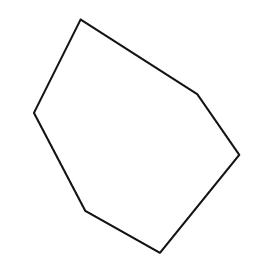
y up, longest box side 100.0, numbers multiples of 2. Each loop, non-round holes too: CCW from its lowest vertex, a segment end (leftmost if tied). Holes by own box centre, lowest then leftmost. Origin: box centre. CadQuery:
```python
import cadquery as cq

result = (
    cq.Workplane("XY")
    .moveTo(10.0, -50.0)
    .lineTo(44.0, -8.0)
    .lineTo(26.0, 18.0)
    .lineTo(-24.0, 50.0)
    .lineTo(-44.0, 10.0)
    .lineTo(-22.0, -32.0)
    .close()
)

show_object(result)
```